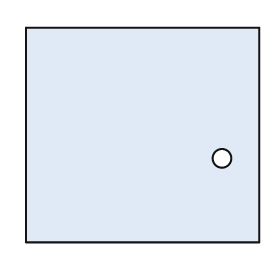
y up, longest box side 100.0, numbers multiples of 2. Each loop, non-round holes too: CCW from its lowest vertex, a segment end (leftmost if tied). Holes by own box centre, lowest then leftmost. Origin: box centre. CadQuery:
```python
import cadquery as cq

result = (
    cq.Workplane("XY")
    .moveTo(-50.0, -46.0)
    .lineTo(50.0, -46.0)
    .lineTo(50.0, 46.0)
    .lineTo(-50.0, 46.0)
    .close()
    .moveTo(34.0, -10.0)
    .circle(4.0)
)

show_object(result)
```